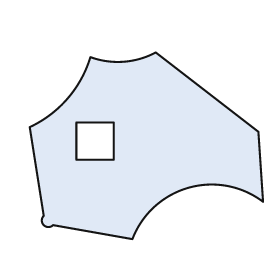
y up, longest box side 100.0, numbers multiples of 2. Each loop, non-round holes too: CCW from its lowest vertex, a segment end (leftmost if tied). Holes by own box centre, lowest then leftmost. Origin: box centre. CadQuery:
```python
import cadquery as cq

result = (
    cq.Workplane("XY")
    .moveTo(-6.0, -40.0)
    .threePointArc((18.0, -18.0), (50.0, -24.0))
    .lineTo(48.0, 6.0)
    .lineTo(4.0, 40.0)
    .threePointArc((-10.0, 36.0), (-24.0, 38.0))
    .threePointArc((-34.0, 20.0), (-50.0, 8.0))
    .lineTo(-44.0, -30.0)
    .threePointArc((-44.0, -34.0), (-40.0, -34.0))
    .close()
    .moveTo(-30.0, -6.0)
    .lineTo(-14.0, -6.0)
    .lineTo(-14.0, 10.0)
    .lineTo(-30.0, 10.0)
    .close()
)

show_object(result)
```